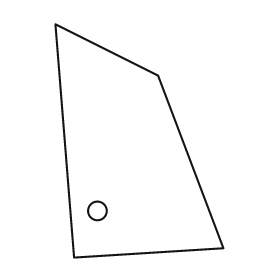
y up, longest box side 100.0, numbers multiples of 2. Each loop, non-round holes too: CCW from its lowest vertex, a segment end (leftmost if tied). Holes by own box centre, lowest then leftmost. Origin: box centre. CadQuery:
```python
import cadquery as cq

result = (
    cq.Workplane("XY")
    .moveTo(-28.0, -50.0)
    .lineTo(36.0, -46.0)
    .lineTo(8.0, 28.0)
    .lineTo(-36.0, 50.0)
    .close()
    .moveTo(-18.0, -30.0)
    .circle(4.0)
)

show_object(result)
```